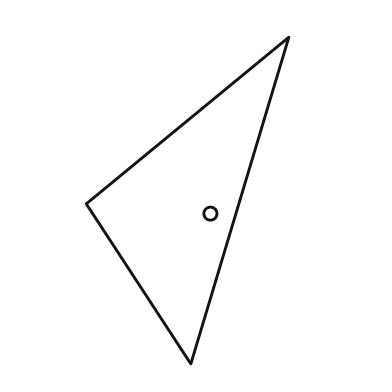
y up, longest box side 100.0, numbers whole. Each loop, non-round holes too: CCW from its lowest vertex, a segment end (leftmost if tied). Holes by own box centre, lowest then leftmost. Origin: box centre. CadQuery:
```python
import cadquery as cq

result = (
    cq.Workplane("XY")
    .moveTo(1.0, -50.0)
    .lineTo(31.0, 50.0)
    .lineTo(-31.0, -1.0)
    .close()
    .moveTo(7.0, -4.0)
    .circle(2.0)
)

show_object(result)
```